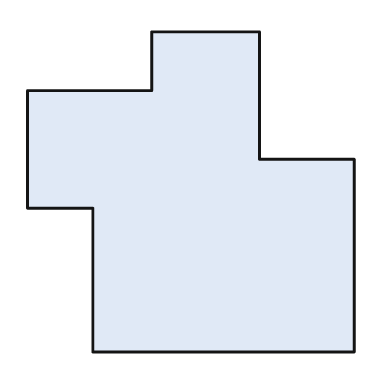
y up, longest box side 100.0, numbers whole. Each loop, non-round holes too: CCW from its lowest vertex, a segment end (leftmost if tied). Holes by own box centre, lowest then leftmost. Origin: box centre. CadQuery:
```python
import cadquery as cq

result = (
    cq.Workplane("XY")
    .moveTo(-30.0, -49.0)
    .lineTo(50.0, -49.0)
    .lineTo(50.0, 10.0)
    .lineTo(21.0, 10.0)
    .lineTo(21.0, 49.0)
    .lineTo(-12.0, 49.0)
    .lineTo(-12.0, 31.0)
    .lineTo(-50.0, 31.0)
    .lineTo(-50.0, -5.0)
    .lineTo(-30.0, -5.0)
    .close()
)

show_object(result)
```